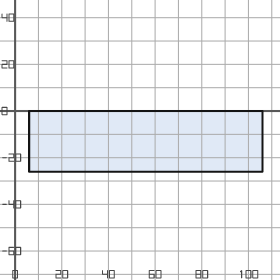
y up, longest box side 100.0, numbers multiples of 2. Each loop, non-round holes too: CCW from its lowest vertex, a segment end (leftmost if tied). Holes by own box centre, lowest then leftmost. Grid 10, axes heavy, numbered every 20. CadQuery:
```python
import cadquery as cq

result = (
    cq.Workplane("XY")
    .moveTo(6.0, -26.0)
    .lineTo(106.0, -26.0)
    .lineTo(106.0, 0.0)
    .lineTo(6.0, 0.0)
    .close()
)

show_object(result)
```